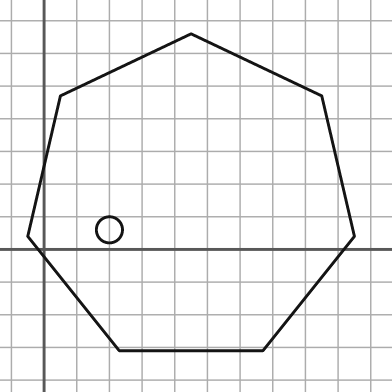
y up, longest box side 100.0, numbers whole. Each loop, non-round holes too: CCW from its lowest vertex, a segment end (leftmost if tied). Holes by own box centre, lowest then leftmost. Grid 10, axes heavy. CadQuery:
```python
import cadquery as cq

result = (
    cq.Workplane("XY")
    .moveTo(23.0, -31.0)
    .lineTo(67.0, -31.0)
    .lineTo(95.0, 4.0)
    .lineTo(85.0, 47.0)
    .lineTo(45.0, 66.0)
    .lineTo(5.0, 47.0)
    .lineTo(-5.0, 4.0)
    .close()
    .moveTo(20.0, 6.0)
    .circle(4.0)
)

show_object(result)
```